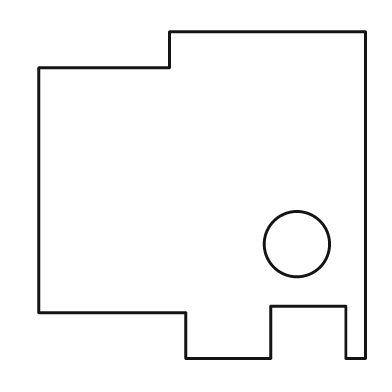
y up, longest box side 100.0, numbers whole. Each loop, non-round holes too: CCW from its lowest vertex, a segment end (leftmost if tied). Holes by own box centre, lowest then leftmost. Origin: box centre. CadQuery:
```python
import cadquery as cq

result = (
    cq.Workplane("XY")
    .moveTo(-5.0, -50.0)
    .lineTo(21.0, -50.0)
    .lineTo(21.0, -34.0)
    .lineTo(44.0, -34.0)
    .lineTo(44.0, -50.0)
    .lineTo(50.0, -50.0)
    .lineTo(50.0, 50.0)
    .lineTo(-10.0, 50.0)
    .lineTo(-10.0, 39.0)
    .lineTo(-50.0, 39.0)
    .lineTo(-50.0, -36.0)
    .lineTo(-5.0, -36.0)
    .close()
    .moveTo(29.0, -15.0)
    .circle(10.0)
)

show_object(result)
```